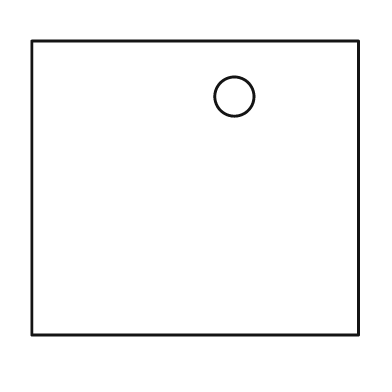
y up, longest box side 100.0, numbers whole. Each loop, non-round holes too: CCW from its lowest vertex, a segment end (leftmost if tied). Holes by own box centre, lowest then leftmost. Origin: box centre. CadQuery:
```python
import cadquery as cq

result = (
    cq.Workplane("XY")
    .moveTo(-50.0, -45.0)
    .lineTo(50.0, -45.0)
    .lineTo(50.0, 45.0)
    .lineTo(-50.0, 45.0)
    .close()
    .moveTo(12.0, 28.0)
    .circle(6.0)
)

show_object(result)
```